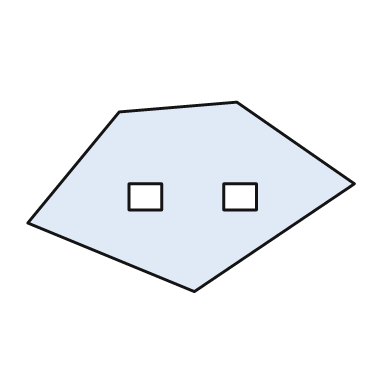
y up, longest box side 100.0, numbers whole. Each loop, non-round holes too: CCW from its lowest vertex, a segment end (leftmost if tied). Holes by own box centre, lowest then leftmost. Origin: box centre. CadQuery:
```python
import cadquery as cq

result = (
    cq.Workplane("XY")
    .moveTo(1.0, -29.0)
    .lineTo(50.0, 4.0)
    .lineTo(14.0, 29.0)
    .lineTo(-22.0, 26.0)
    .lineTo(-50.0, -8.0)
    .close()
    .moveTo(-19.0, -4.0)
    .lineTo(-9.0, -4.0)
    .lineTo(-9.0, 4.0)
    .lineTo(-19.0, 4.0)
    .close()
    .moveTo(10.0, -4.0)
    .lineTo(20.0, -4.0)
    .lineTo(20.0, 4.0)
    .lineTo(10.0, 4.0)
    .close()
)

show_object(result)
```